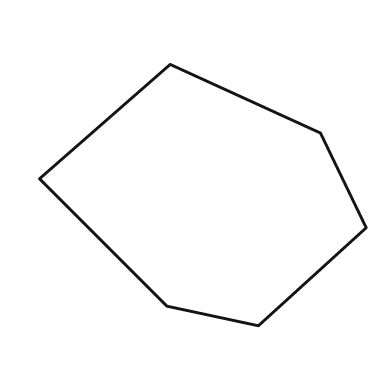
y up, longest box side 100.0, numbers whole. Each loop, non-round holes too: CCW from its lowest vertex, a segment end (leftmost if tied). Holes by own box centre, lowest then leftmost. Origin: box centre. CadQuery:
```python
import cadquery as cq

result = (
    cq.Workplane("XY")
    .moveTo(17.0, -40.0)
    .lineTo(50.0, -10.0)
    .lineTo(36.0, 19.0)
    .lineTo(-10.0, 40.0)
    .lineTo(-50.0, 5.0)
    .lineTo(-11.0, -34.0)
    .close()
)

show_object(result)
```